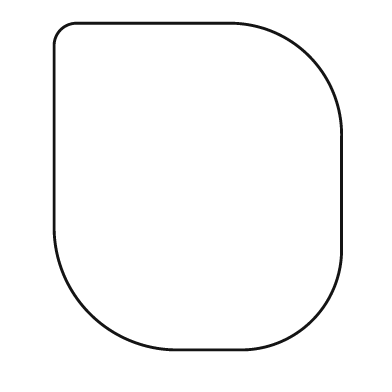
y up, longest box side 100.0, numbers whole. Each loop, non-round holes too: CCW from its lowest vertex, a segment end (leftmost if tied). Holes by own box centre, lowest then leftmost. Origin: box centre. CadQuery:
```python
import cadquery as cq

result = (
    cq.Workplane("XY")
    .moveTo(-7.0, -50.0)
    .lineTo(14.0, -50.0)
    .threePointArc((35.0, -41.0), (44.0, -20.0))
    .lineTo(44.0, 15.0)
    .threePointArc((34.0, 40.0), (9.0, 50.0))
    .lineTo(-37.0, 50.0)
    .threePointArc((-42.0, 48.0), (-44.0, 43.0))
    .lineTo(-44.0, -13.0)
    .threePointArc((-33.0, -39.0), (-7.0, -50.0))
    .close()
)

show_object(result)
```